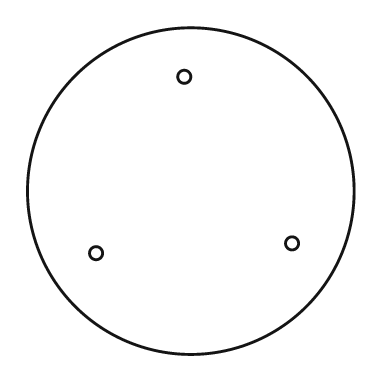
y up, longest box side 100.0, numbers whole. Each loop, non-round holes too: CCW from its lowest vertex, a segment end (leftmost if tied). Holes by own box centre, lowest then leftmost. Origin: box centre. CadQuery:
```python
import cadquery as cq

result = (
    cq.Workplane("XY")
    .moveTo(0.0, 0.0)
    .circle(50.0)
    .moveTo(-29.0, -19.0)
    .circle(2.0)
    .moveTo(31.0, -16.0)
    .circle(2.0)
    .moveTo(-2.0, 35.0)
    .circle(2.0)
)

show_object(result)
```